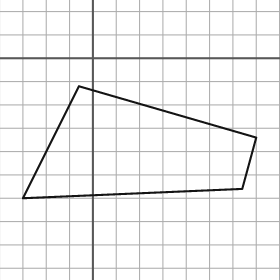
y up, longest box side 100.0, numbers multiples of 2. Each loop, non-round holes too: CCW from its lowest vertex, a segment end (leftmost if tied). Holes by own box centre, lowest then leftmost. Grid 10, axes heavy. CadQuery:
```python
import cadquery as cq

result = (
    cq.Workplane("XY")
    .moveTo(-30.0, -60.0)
    .lineTo(64.0, -56.0)
    .lineTo(70.0, -34.0)
    .lineTo(-6.0, -12.0)
    .close()
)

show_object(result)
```